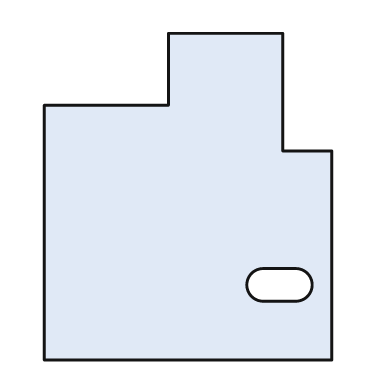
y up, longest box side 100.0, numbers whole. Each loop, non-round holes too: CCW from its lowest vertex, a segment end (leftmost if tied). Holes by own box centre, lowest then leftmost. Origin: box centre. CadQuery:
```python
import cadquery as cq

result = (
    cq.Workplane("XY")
    .moveTo(-44.0, -50.0)
    .lineTo(44.0, -50.0)
    .lineTo(44.0, 14.0)
    .lineTo(29.0, 14.0)
    .lineTo(29.0, 50.0)
    .lineTo(-6.0, 50.0)
    .lineTo(-6.0, 28.0)
    .lineTo(-44.0, 28.0)
    .close()
    .moveTo(23.0, -32.0)
    .lineTo(33.0, -32.0)
    .threePointArc((38.0, -27.0), (33.0, -22.0))
    .lineTo(23.0, -22.0)
    .threePointArc((18.0, -27.0), (23.0, -32.0))
    .close()
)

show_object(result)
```